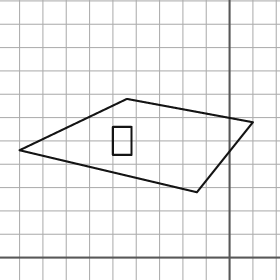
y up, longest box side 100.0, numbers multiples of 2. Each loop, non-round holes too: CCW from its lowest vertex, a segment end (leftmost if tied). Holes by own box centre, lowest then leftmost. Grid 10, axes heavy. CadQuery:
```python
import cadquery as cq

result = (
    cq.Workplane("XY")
    .moveTo(-14.0, 28.0)
    .lineTo(10.0, 58.0)
    .lineTo(-44.0, 68.0)
    .lineTo(-90.0, 46.0)
    .close()
    .moveTo(-50.0, 44.0)
    .lineTo(-42.0, 44.0)
    .lineTo(-42.0, 56.0)
    .lineTo(-50.0, 56.0)
    .close()
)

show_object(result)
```